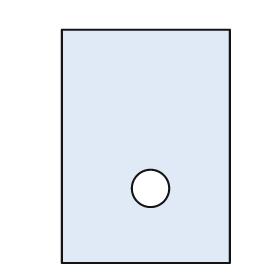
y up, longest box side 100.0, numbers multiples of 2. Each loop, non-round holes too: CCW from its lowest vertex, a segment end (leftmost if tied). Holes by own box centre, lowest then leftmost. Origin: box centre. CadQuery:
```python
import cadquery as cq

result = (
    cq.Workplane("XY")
    .moveTo(-36.0, -50.0)
    .lineTo(36.0, -50.0)
    .lineTo(36.0, 50.0)
    .lineTo(-36.0, 50.0)
    .close()
    .moveTo(2.0, -18.0)
    .circle(8.0)
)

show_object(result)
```